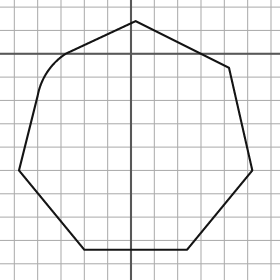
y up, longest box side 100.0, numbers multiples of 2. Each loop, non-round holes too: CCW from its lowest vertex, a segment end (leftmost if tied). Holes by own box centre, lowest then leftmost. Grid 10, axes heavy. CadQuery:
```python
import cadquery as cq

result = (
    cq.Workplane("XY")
    .moveTo(-20.0, -84.0)
    .lineTo(24.0, -84.0)
    .lineTo(52.0, -50.0)
    .lineTo(42.0, -6.0)
    .lineTo(2.0, 14.0)
    .lineTo(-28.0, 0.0)
    .threePointArc((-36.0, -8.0), (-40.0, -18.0))
    .lineTo(-48.0, -50.0)
    .close()
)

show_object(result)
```